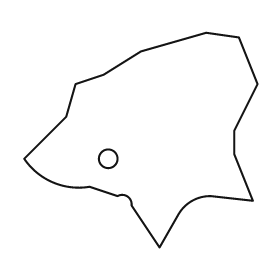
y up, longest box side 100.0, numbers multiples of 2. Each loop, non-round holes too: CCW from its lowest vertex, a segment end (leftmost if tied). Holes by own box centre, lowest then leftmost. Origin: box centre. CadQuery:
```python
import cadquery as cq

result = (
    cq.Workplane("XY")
    .moveTo(8.0, -46.0)
    .lineTo(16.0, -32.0)
    .threePointArc((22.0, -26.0), (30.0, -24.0))
    .lineTo(48.0, -26.0)
    .lineTo(40.0, -6.0)
    .lineTo(40.0, 4.0)
    .lineTo(50.0, 24.0)
    .lineTo(42.0, 44.0)
    .lineTo(28.0, 46.0)
    .lineTo(0.0, 38.0)
    .lineTo(-16.0, 28.0)
    .lineTo(-28.0, 24.0)
    .lineTo(-32.0, 10.0)
    .lineTo(-50.0, -8.0)
    .threePointArc((-38.0, -18.0), (-22.0, -20.0))
    .lineTo(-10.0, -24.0)
    .threePointArc((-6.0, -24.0), (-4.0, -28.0))
    .close()
    .moveTo(-14.0, -8.0)
    .circle(4.0)
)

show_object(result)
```